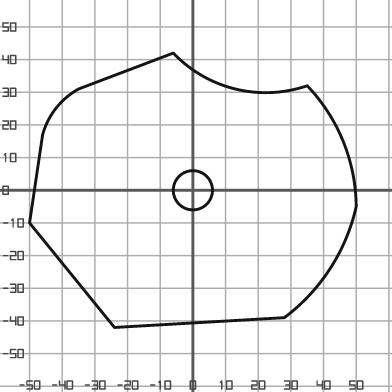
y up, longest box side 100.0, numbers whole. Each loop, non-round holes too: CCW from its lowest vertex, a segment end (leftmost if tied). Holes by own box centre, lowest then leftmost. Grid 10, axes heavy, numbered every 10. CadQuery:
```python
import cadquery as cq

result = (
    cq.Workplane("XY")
    .moveTo(-24.0, -42.0)
    .lineTo(28.0, -39.0)
    .threePointArc((42.0, -24.0), (50.0, -5.0))
    .threePointArc((46.0, 15.0), (35.0, 32.0))
    .threePointArc((13.0, 31.0), (-6.0, 42.0))
    .lineTo(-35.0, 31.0)
    .threePointArc((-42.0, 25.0), (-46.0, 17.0))
    .lineTo(-50.0, -10.0)
    .close()
    .moveTo(0.0, 0.0)
    .circle(6.0)
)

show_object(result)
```